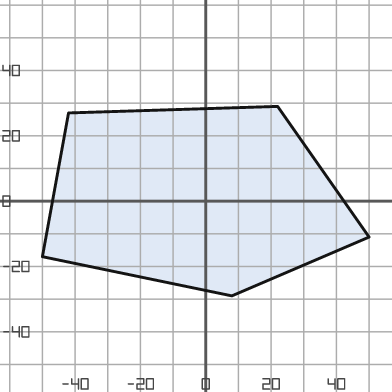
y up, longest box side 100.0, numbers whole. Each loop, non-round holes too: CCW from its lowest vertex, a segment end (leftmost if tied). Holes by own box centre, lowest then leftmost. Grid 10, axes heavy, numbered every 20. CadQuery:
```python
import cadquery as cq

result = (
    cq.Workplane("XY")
    .moveTo(8.0, -29.0)
    .lineTo(50.0, -11.0)
    .lineTo(22.0, 29.0)
    .lineTo(-42.0, 27.0)
    .lineTo(-50.0, -17.0)
    .close()
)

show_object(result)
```